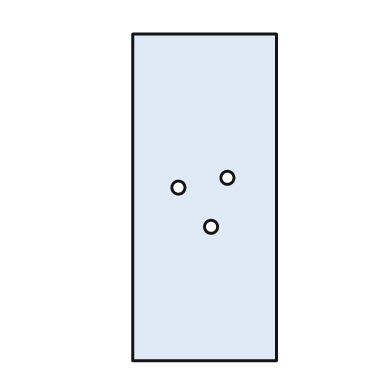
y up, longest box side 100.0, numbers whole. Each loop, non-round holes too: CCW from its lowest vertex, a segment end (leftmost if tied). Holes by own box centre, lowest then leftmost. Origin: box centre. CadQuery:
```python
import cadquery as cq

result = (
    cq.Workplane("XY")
    .moveTo(-22.0, -50.0)
    .lineTo(22.0, -50.0)
    .lineTo(22.0, 50.0)
    .lineTo(-22.0, 50.0)
    .close()
    .moveTo(2.0, -9.0)
    .circle(2.0)
    .moveTo(-8.0, 3.0)
    .circle(2.0)
    .moveTo(7.0, 6.0)
    .circle(2.0)
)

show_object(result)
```